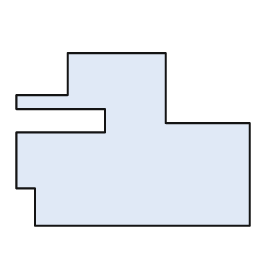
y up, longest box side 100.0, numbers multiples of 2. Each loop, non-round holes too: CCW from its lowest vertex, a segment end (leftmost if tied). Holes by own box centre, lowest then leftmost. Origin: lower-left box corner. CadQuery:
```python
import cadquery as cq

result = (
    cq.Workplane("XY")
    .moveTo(8.0, 0.0)
    .lineTo(100.0, 0.0)
    .lineTo(100.0, 44.0)
    .lineTo(64.0, 44.0)
    .lineTo(64.0, 74.0)
    .lineTo(22.0, 74.0)
    .lineTo(22.0, 56.0)
    .lineTo(0.0, 56.0)
    .lineTo(0.0, 50.0)
    .lineTo(38.0, 50.0)
    .lineTo(38.0, 40.0)
    .lineTo(0.0, 40.0)
    .lineTo(0.0, 16.0)
    .lineTo(8.0, 16.0)
    .close()
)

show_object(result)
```